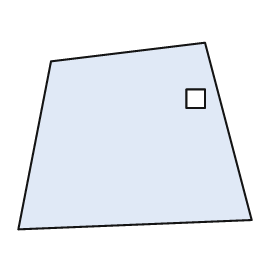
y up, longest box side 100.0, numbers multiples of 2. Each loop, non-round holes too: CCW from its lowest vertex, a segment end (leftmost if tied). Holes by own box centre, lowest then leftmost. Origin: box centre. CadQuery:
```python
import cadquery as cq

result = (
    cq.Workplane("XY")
    .moveTo(-50.0, -40.0)
    .lineTo(50.0, -36.0)
    .lineTo(30.0, 40.0)
    .lineTo(-36.0, 32.0)
    .close()
    .moveTo(22.0, 12.0)
    .lineTo(30.0, 12.0)
    .lineTo(30.0, 20.0)
    .lineTo(22.0, 20.0)
    .close()
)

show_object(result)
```